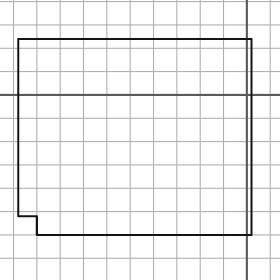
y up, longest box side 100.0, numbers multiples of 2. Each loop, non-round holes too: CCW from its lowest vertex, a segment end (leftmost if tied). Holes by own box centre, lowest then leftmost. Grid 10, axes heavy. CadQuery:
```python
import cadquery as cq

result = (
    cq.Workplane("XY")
    .moveTo(-90.0, -60.0)
    .lineTo(2.0, -60.0)
    .lineTo(2.0, 24.0)
    .lineTo(-98.0, 24.0)
    .lineTo(-98.0, -52.0)
    .lineTo(-90.0, -52.0)
    .close()
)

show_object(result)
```